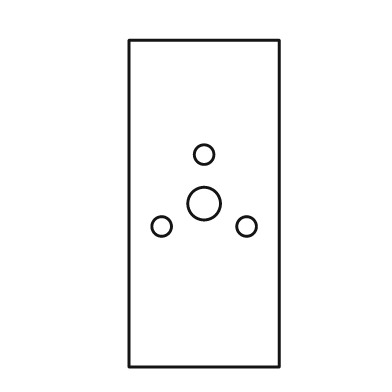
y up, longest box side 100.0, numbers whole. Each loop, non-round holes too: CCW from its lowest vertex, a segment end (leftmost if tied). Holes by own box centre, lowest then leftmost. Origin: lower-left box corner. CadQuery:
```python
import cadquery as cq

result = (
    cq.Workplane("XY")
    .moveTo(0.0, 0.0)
    .lineTo(46.0, 0.0)
    .lineTo(46.0, 100.0)
    .lineTo(0.0, 100.0)
    .close()
    .moveTo(10.0, 43.0)
    .circle(3.0)
    .moveTo(36.0, 43.0)
    .circle(3.0)
    .moveTo(23.0, 50.0)
    .circle(5.0)
    .moveTo(23.0, 65.0)
    .circle(3.0)
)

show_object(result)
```